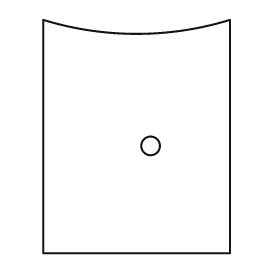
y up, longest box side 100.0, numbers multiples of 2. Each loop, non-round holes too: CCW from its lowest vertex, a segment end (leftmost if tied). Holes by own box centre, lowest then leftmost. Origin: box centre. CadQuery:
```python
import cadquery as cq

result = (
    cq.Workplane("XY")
    .moveTo(-40.0, -50.0)
    .lineTo(40.0, -50.0)
    .lineTo(40.0, 50.0)
    .threePointArc((0.0, 44.0), (-40.0, 50.0))
    .close()
    .moveTo(6.0, -4.0)
    .circle(4.0)
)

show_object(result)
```